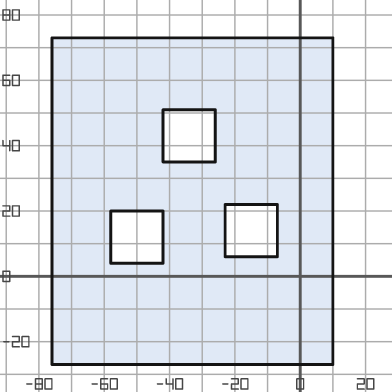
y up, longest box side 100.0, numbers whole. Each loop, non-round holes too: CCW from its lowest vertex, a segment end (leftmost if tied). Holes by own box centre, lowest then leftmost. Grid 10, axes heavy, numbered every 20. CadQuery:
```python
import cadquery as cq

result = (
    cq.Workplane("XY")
    .moveTo(-76.0, -27.0)
    .lineTo(10.0, -27.0)
    .lineTo(10.0, 73.0)
    .lineTo(-76.0, 73.0)
    .close()
    .moveTo(-58.0, 4.0)
    .lineTo(-42.0, 4.0)
    .lineTo(-42.0, 20.0)
    .lineTo(-58.0, 20.0)
    .close()
    .moveTo(-23.0, 6.0)
    .lineTo(-7.0, 6.0)
    .lineTo(-7.0, 22.0)
    .lineTo(-23.0, 22.0)
    .close()
    .moveTo(-42.0, 35.0)
    .lineTo(-26.0, 35.0)
    .lineTo(-26.0, 51.0)
    .lineTo(-42.0, 51.0)
    .close()
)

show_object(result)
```